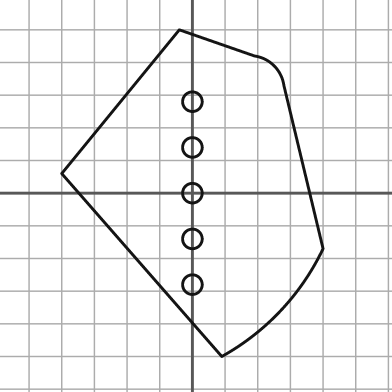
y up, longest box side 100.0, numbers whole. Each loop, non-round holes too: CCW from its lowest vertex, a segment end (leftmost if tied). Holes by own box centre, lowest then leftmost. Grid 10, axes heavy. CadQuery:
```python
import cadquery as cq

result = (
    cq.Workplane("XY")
    .moveTo(9.0, -50.0)
    .threePointArc((27.0, -36.0), (40.0, -17.0))
    .lineTo(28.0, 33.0)
    .threePointArc((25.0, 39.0), (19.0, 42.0))
    .lineTo(-4.0, 50.0)
    .lineTo(-40.0, 6.0)
    .close()
    .moveTo(0.0, -28.0)
    .circle(3.0)
    .moveTo(0.0, -14.0)
    .circle(3.0)
    .moveTo(0.0, 0.0)
    .circle(3.0)
    .moveTo(0.0, 14.0)
    .circle(3.0)
    .moveTo(0.0, 28.0)
    .circle(3.0)
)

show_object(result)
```